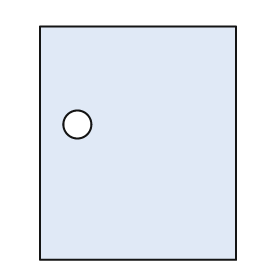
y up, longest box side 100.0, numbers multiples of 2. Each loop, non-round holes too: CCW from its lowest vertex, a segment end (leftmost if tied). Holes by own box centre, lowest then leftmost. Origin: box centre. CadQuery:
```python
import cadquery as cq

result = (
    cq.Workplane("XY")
    .moveTo(-42.0, -50.0)
    .lineTo(42.0, -50.0)
    .lineTo(42.0, 50.0)
    .lineTo(-42.0, 50.0)
    .close()
    .moveTo(-26.0, 8.0)
    .circle(6.0)
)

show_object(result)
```